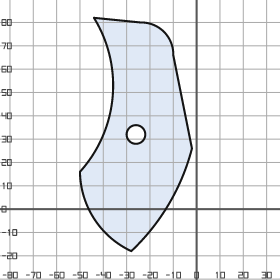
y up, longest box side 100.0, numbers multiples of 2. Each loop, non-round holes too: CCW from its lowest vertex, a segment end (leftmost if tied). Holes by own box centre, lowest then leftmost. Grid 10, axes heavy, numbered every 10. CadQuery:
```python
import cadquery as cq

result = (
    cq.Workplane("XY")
    .moveTo(-28.0, -18.0)
    .threePointArc((-12.0, 2.0), (-2.0, 26.0))
    .lineTo(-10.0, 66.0)
    .threePointArc((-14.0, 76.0), (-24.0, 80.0))
    .lineTo(-44.0, 82.0)
    .threePointArc((-36.0, 48.0), (-50.0, 16.0))
    .threePointArc((-44.0, -4.0), (-28.0, -18.0))
    .close()
    .moveTo(-26.0, 32.0)
    .circle(4.0)
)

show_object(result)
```